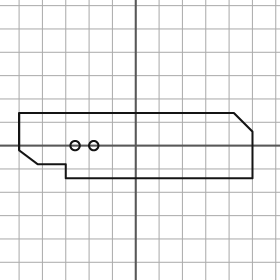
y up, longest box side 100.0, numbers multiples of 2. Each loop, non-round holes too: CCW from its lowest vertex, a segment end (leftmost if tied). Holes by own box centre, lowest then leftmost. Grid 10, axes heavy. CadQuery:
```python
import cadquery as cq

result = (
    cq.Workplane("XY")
    .moveTo(-30.0, -14.0)
    .lineTo(50.0, -14.0)
    .lineTo(50.0, 6.0)
    .lineTo(42.0, 14.0)
    .lineTo(-50.0, 14.0)
    .lineTo(-50.0, -2.0)
    .lineTo(-42.0, -8.0)
    .lineTo(-30.0, -8.0)
    .close()
    .moveTo(-26.0, 0.0)
    .circle(2.0)
    .moveTo(-18.0, 0.0)
    .circle(2.0)
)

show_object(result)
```